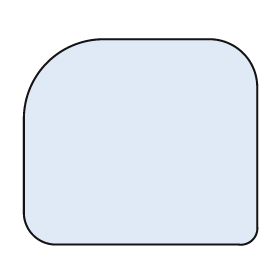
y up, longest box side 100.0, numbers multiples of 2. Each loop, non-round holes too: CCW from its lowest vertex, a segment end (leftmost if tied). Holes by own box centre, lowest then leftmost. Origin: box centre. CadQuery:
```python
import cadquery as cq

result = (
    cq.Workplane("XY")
    .moveTo(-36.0, -44.0)
    .lineTo(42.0, -44.0)
    .threePointArc((48.0, -42.0), (50.0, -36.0))
    .lineTo(50.0, 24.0)
    .threePointArc((44.0, 38.0), (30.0, 44.0))
    .lineTo(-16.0, 44.0)
    .threePointArc((-40.0, 34.0), (-50.0, 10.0))
    .lineTo(-50.0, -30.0)
    .threePointArc((-46.0, -40.0), (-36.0, -44.0))
    .close()
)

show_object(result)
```